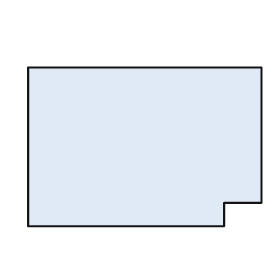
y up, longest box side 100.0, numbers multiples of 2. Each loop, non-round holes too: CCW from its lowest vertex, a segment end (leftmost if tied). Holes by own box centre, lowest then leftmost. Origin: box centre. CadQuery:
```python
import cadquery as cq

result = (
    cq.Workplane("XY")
    .moveTo(-50.0, -34.0)
    .lineTo(34.0, -34.0)
    .lineTo(34.0, -24.0)
    .lineTo(50.0, -24.0)
    .lineTo(50.0, 34.0)
    .lineTo(-50.0, 34.0)
    .close()
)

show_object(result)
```